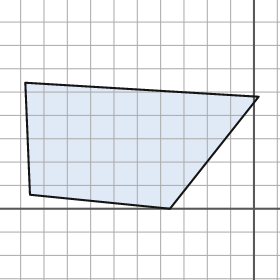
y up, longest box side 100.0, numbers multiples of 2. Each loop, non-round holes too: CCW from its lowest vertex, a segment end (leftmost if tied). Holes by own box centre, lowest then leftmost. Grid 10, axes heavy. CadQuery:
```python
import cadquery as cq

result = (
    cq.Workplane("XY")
    .moveTo(-36.0, 0.0)
    .lineTo(2.0, 48.0)
    .lineTo(-98.0, 54.0)
    .lineTo(-96.0, 6.0)
    .close()
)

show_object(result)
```